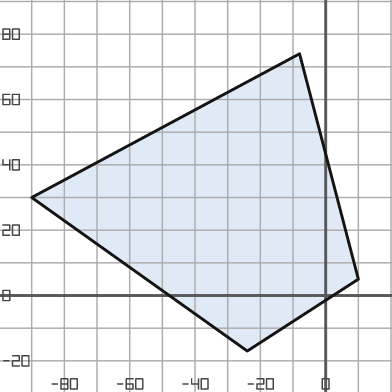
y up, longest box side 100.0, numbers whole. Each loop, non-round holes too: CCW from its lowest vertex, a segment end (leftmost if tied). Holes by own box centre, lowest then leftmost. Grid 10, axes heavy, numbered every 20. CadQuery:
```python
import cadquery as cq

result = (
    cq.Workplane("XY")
    .moveTo(-24.0, -17.0)
    .lineTo(10.0, 5.0)
    .lineTo(-8.0, 74.0)
    .lineTo(-90.0, 30.0)
    .close()
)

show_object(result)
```